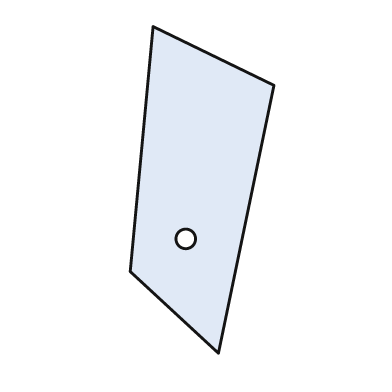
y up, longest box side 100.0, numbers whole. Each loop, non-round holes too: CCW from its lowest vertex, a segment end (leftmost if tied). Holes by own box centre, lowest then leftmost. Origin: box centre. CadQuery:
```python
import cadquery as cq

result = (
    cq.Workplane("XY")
    .moveTo(5.0, -50.0)
    .lineTo(22.0, 32.0)
    .lineTo(-15.0, 50.0)
    .lineTo(-22.0, -25.0)
    .close()
    .moveTo(-5.0, -15.0)
    .circle(3.0)
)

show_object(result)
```